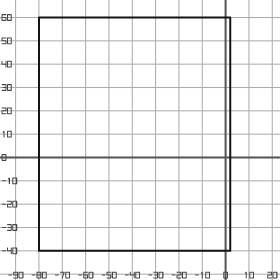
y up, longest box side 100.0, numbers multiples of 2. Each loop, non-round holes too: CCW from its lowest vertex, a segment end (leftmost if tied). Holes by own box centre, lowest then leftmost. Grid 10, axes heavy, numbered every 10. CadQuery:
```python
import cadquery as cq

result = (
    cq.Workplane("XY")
    .moveTo(-80.0, -40.0)
    .lineTo(2.0, -40.0)
    .lineTo(2.0, 60.0)
    .lineTo(-80.0, 60.0)
    .close()
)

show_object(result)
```